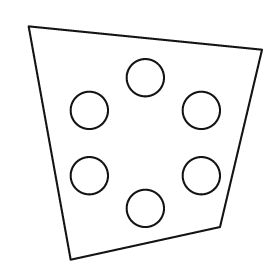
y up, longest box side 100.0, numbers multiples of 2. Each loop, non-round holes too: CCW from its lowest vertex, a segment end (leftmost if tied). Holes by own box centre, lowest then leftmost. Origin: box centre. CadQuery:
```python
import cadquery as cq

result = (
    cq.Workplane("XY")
    .moveTo(-32.0, -50.0)
    .lineTo(32.0, -36.0)
    .lineTo(50.0, 40.0)
    .lineTo(-50.0, 50.0)
    .close()
    .moveTo(0.0, -28.0)
    .circle(8.0)
    .moveTo(-24.0, -14.0)
    .circle(8.0)
    .moveTo(24.0, -14.0)
    .circle(8.0)
    .moveTo(-24.0, 14.0)
    .circle(8.0)
    .moveTo(24.0, 14.0)
    .circle(8.0)
    .moveTo(0.0, 28.0)
    .circle(8.0)
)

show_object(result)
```